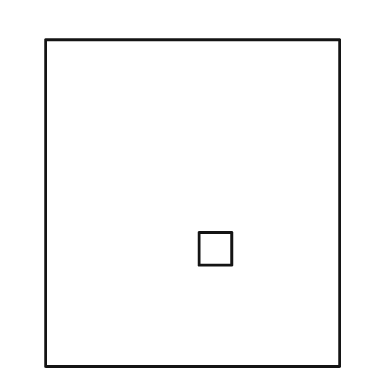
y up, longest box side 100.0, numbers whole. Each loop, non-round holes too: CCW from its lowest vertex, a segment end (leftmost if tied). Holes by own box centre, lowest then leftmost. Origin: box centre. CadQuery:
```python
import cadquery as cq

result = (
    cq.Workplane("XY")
    .moveTo(-45.0, -50.0)
    .lineTo(45.0, -50.0)
    .lineTo(45.0, 50.0)
    .lineTo(-45.0, 50.0)
    .close()
    .moveTo(2.0, -19.0)
    .lineTo(12.0, -19.0)
    .lineTo(12.0, -9.0)
    .lineTo(2.0, -9.0)
    .close()
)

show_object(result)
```